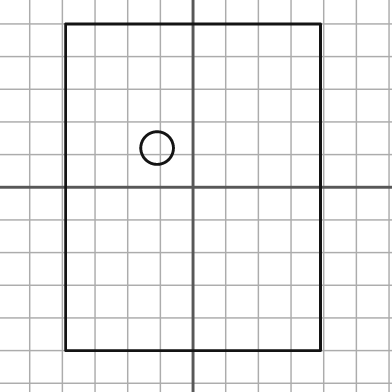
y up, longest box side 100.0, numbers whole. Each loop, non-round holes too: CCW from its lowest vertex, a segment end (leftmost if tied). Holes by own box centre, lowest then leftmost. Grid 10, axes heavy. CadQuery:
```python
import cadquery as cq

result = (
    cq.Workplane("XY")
    .moveTo(-39.0, -50.0)
    .lineTo(39.0, -50.0)
    .lineTo(39.0, 50.0)
    .lineTo(-39.0, 50.0)
    .close()
    .moveTo(-11.0, 12.0)
    .circle(5.0)
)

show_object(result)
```